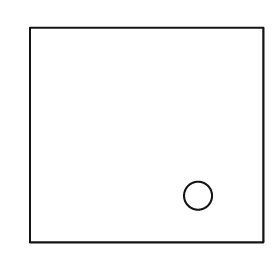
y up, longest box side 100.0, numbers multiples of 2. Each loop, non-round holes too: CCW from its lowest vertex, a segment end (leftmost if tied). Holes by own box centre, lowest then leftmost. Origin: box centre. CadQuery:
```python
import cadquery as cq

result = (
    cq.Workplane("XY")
    .moveTo(-50.0, -46.0)
    .lineTo(50.0, -46.0)
    .lineTo(50.0, 46.0)
    .lineTo(-50.0, 46.0)
    .close()
    .moveTo(22.0, -26.0)
    .circle(6.0)
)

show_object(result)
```